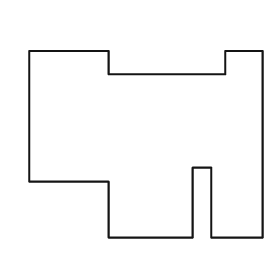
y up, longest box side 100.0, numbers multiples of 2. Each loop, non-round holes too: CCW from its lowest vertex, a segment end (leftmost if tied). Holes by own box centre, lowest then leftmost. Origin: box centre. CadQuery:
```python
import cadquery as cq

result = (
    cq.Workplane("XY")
    .moveTo(-16.0, -40.0)
    .lineTo(20.0, -40.0)
    .lineTo(20.0, -10.0)
    .lineTo(28.0, -10.0)
    .lineTo(28.0, -40.0)
    .lineTo(50.0, -40.0)
    .lineTo(50.0, 40.0)
    .lineTo(34.0, 40.0)
    .lineTo(34.0, 30.0)
    .lineTo(-16.0, 30.0)
    .lineTo(-16.0, 40.0)
    .lineTo(-50.0, 40.0)
    .lineTo(-50.0, -16.0)
    .lineTo(-16.0, -16.0)
    .close()
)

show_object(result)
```